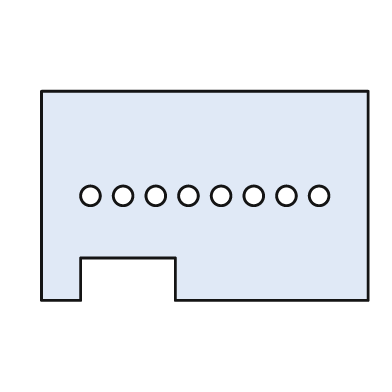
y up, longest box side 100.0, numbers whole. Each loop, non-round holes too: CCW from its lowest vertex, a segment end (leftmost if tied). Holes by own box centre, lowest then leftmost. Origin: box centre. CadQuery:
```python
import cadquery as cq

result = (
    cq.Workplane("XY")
    .moveTo(-50.0, -32.0)
    .lineTo(-38.0, -32.0)
    .lineTo(-38.0, -19.0)
    .lineTo(-9.0, -19.0)
    .lineTo(-9.0, -32.0)
    .lineTo(50.0, -32.0)
    .lineTo(50.0, 32.0)
    .lineTo(-50.0, 32.0)
    .close()
    .moveTo(-35.0, 0.0)
    .circle(3.0)
    .moveTo(-25.0, 0.0)
    .circle(3.0)
    .moveTo(-15.0, 0.0)
    .circle(3.0)
    .moveTo(-5.0, 0.0)
    .circle(3.0)
    .moveTo(5.0, 0.0)
    .circle(3.0)
    .moveTo(15.0, 0.0)
    .circle(3.0)
    .moveTo(25.0, 0.0)
    .circle(3.0)
    .moveTo(35.0, 0.0)
    .circle(3.0)
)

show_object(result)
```